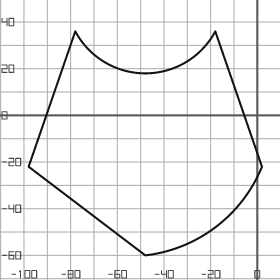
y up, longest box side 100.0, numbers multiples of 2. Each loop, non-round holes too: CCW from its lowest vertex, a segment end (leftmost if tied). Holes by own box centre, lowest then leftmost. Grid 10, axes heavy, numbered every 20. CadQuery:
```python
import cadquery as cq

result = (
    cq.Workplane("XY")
    .moveTo(-48.0, -60.0)
    .threePointArc((-18.0, -48.0), (2.0, -22.0))
    .lineTo(-18.0, 36.0)
    .threePointArc((-48.0, 18.0), (-78.0, 36.0))
    .lineTo(-98.0, -22.0)
    .close()
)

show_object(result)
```